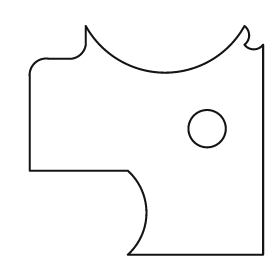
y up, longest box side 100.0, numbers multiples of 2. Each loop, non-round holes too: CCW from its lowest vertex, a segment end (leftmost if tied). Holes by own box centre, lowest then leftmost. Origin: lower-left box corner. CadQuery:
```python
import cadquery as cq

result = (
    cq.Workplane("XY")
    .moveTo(42.0, 0.0)
    .lineTo(100.0, 0.0)
    .lineTo(100.0, 90.0)
    .threePointArc((96.0, 88.0), (92.0, 90.0))
    .threePointArc((94.0, 94.0), (92.0, 98.0))
    .threePointArc((58.0, 78.0), (24.0, 98.0))
    .lineTo(24.0, 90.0)
    .threePointArc((22.0, 86.0), (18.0, 84.0))
    .lineTo(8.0, 84.0)
    .threePointArc((2.0, 82.0), (0.0, 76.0))
    .lineTo(0.0, 36.0)
    .lineTo(42.0, 36.0)
    .threePointArc((50.0, 18.0), (42.0, 0.0))
    .close()
    .moveTo(76.0, 54.0)
    .circle(8.0)
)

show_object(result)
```